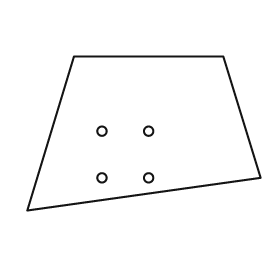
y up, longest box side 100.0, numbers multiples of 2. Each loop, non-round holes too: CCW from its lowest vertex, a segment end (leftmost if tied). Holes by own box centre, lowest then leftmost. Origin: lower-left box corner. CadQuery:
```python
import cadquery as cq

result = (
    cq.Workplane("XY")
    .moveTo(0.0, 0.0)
    .lineTo(100.0, 14.0)
    .lineTo(84.0, 66.0)
    .lineTo(20.0, 66.0)
    .close()
    .moveTo(32.0, 14.0)
    .circle(2.0)
    .moveTo(52.0, 14.0)
    .circle(2.0)
    .moveTo(32.0, 34.0)
    .circle(2.0)
    .moveTo(52.0, 34.0)
    .circle(2.0)
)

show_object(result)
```